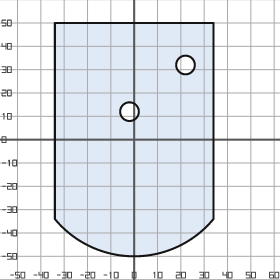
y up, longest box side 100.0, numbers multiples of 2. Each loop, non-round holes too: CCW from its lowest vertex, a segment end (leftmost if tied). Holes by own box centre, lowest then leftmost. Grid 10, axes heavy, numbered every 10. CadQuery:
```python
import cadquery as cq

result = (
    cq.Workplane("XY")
    .moveTo(-34.0, -34.0)
    .threePointArc((0.0, -50.0), (34.0, -34.0))
    .lineTo(34.0, 50.0)
    .lineTo(-34.0, 50.0)
    .close()
    .moveTo(-2.0, 12.0)
    .circle(4.0)
    .moveTo(22.0, 32.0)
    .circle(4.0)
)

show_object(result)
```